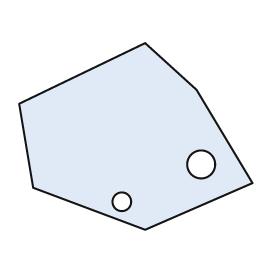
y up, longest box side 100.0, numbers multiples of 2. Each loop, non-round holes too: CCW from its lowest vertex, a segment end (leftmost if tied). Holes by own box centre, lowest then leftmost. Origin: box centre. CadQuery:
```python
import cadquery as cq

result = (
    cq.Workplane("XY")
    .moveTo(4.0, -40.0)
    .lineTo(50.0, -20.0)
    .lineTo(26.0, 20.0)
    .lineTo(4.0, 40.0)
    .lineTo(-50.0, 14.0)
    .lineTo(-44.0, -22.0)
    .close()
    .moveTo(-6.0, -28.0)
    .circle(4.0)
    .moveTo(28.0, -12.0)
    .circle(6.0)
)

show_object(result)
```